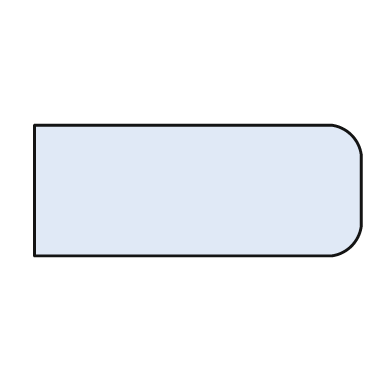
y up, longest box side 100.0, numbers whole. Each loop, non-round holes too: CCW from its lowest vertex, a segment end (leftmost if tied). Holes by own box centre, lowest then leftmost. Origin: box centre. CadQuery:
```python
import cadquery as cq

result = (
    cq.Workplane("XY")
    .moveTo(-50.0, -20.0)
    .lineTo(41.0, -20.0)
    .threePointArc((47.0, -17.0), (50.0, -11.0))
    .lineTo(50.0, 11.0)
    .threePointArc((47.0, 17.0), (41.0, 20.0))
    .lineTo(-50.0, 20.0)
    .close()
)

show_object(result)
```